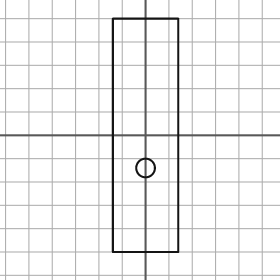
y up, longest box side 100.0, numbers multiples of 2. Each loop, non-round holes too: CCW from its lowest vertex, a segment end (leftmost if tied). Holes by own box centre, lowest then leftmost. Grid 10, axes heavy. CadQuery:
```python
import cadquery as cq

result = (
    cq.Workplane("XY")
    .moveTo(-14.0, -50.0)
    .lineTo(14.0, -50.0)
    .lineTo(14.0, 50.0)
    .lineTo(-14.0, 50.0)
    .close()
    .moveTo(0.0, -14.0)
    .circle(4.0)
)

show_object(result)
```